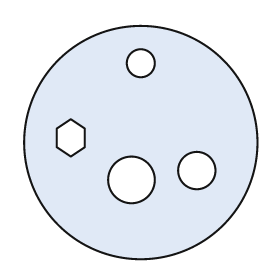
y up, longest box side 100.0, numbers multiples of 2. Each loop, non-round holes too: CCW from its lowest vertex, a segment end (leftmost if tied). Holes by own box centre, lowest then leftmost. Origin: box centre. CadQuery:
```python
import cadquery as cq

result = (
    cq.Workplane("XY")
    .moveTo(0.0, 0.0)
    .circle(50.0)
    .moveTo(-4.0, -16.0)
    .circle(10.0)
    .moveTo(24.0, -12.0)
    .circle(8.0)
    .moveTo(-30.0, -6.0)
    .lineTo(-24.0, -2.0)
    .lineTo(-24.0, 6.0)
    .lineTo(-30.0, 10.0)
    .lineTo(-36.0, 6.0)
    .lineTo(-36.0, -2.0)
    .close()
    .moveTo(0.0, 34.0)
    .circle(6.0)
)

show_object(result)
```